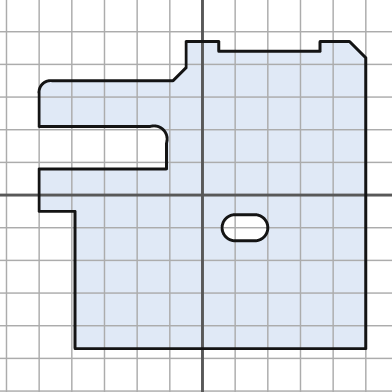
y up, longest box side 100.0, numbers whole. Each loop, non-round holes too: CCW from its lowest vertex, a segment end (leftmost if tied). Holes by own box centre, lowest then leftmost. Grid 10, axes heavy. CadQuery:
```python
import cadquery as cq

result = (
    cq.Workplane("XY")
    .moveTo(-39.0, -47.0)
    .lineTo(50.0, -47.0)
    .lineTo(50.0, 42.0)
    .lineTo(45.0, 47.0)
    .lineTo(36.0, 47.0)
    .lineTo(36.0, 44.0)
    .lineTo(5.0, 44.0)
    .lineTo(5.0, 47.0)
    .lineTo(-5.0, 47.0)
    .lineTo(-5.0, 39.0)
    .lineTo(-9.0, 35.0)
    .lineTo(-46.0, 35.0)
    .threePointArc((-49.0, 34.0), (-50.0, 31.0))
    .lineTo(-50.0, 21.0)
    .lineTo(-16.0, 21.0)
    .threePointArc((-12.0, 20.0), (-11.0, 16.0))
    .lineTo(-11.0, 8.0)
    .lineTo(-50.0, 8.0)
    .lineTo(-50.0, -5.0)
    .lineTo(-39.0, -5.0)
    .close()
    .moveTo(10.0, -14.0)
    .lineTo(16.0, -14.0)
    .threePointArc((20.0, -10.0), (16.0, -6.0))
    .lineTo(10.0, -6.0)
    .threePointArc((6.0, -10.0), (10.0, -14.0))
    .close()
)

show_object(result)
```